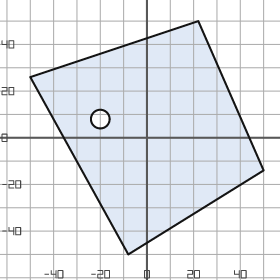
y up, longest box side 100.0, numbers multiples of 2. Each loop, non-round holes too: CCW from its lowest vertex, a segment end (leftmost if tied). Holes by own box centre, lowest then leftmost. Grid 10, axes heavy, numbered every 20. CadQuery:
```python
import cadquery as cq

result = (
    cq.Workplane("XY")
    .moveTo(-8.0, -50.0)
    .lineTo(50.0, -14.0)
    .lineTo(22.0, 50.0)
    .lineTo(-50.0, 26.0)
    .close()
    .moveTo(-20.0, 8.0)
    .circle(4.0)
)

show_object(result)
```